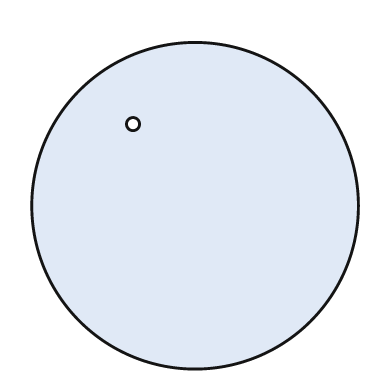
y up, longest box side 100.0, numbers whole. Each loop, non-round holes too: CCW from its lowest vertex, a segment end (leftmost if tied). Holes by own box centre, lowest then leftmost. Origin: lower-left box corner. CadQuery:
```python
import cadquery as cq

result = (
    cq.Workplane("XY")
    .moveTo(50.0, 50.0)
    .circle(50.0)
    .moveTo(31.0, 75.0)
    .circle(2.0)
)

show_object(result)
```